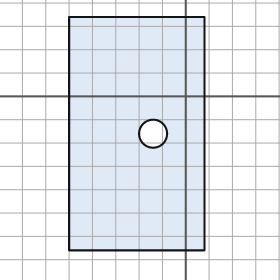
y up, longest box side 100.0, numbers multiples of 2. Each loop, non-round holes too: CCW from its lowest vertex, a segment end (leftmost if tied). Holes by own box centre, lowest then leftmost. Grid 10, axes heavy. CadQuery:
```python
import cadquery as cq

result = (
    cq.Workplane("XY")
    .moveTo(-50.0, -66.0)
    .lineTo(8.0, -66.0)
    .lineTo(8.0, 34.0)
    .lineTo(-50.0, 34.0)
    .close()
    .moveTo(-14.0, -16.0)
    .circle(6.0)
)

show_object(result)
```